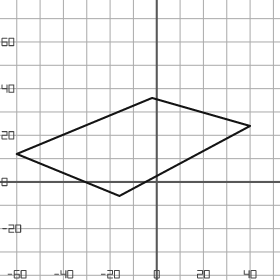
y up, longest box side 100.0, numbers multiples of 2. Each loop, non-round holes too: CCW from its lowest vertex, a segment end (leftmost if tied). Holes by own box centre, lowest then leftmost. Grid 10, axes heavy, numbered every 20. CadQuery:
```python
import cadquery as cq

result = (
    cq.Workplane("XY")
    .moveTo(-16.0, -6.0)
    .lineTo(40.0, 24.0)
    .lineTo(-2.0, 36.0)
    .lineTo(-60.0, 12.0)
    .close()
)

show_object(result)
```